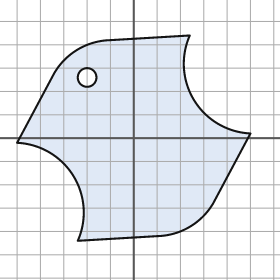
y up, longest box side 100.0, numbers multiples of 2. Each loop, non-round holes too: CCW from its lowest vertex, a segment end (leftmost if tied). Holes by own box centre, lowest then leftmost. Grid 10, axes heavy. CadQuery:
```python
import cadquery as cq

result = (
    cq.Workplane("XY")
    .moveTo(-24.0, -44.0)
    .lineTo(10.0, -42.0)
    .threePointArc((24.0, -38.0), (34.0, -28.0))
    .lineTo(50.0, 2.0)
    .threePointArc((26.0, 16.0), (24.0, 44.0))
    .lineTo(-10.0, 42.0)
    .threePointArc((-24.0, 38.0), (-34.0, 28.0))
    .lineTo(-50.0, -2.0)
    .threePointArc((-26.0, -16.0), (-24.0, -44.0))
    .close()
    .moveTo(-20.0, 26.0)
    .circle(4.0)
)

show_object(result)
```